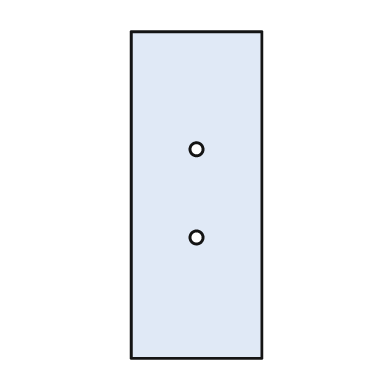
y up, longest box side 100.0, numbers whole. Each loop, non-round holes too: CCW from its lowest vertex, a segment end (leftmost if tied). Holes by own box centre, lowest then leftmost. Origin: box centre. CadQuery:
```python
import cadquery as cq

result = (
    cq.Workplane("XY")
    .moveTo(-20.0, -50.0)
    .lineTo(20.0, -50.0)
    .lineTo(20.0, 50.0)
    .lineTo(-20.0, 50.0)
    .close()
    .moveTo(0.0, -13.0)
    .circle(2.0)
    .moveTo(0.0, 14.0)
    .circle(2.0)
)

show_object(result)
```